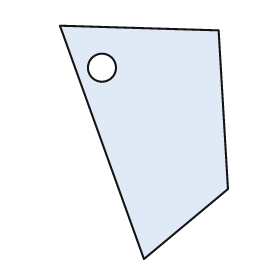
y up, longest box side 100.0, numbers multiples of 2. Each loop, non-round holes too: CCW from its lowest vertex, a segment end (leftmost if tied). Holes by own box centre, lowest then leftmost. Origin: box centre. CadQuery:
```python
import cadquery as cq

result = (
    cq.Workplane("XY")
    .moveTo(0.0, -50.0)
    .lineTo(36.0, -20.0)
    .lineTo(32.0, 48.0)
    .lineTo(-36.0, 50.0)
    .close()
    .moveTo(-18.0, 32.0)
    .circle(6.0)
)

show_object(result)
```